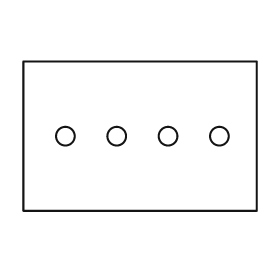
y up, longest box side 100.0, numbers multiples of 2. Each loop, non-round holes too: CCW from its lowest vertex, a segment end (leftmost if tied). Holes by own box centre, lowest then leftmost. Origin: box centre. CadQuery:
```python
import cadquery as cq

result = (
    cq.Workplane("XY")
    .moveTo(-50.0, -32.0)
    .lineTo(50.0, -32.0)
    .lineTo(50.0, 32.0)
    .lineTo(-50.0, 32.0)
    .close()
    .moveTo(-32.0, 0.0)
    .circle(4.0)
    .moveTo(-10.0, 0.0)
    .circle(4.0)
    .moveTo(12.0, 0.0)
    .circle(4.0)
    .moveTo(34.0, 0.0)
    .circle(4.0)
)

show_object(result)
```